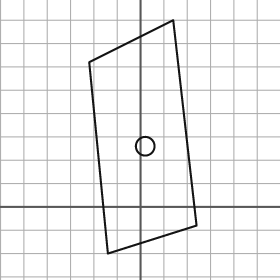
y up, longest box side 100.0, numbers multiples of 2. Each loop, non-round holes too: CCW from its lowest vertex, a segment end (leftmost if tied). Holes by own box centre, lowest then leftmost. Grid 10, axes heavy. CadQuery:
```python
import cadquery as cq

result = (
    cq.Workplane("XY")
    .moveTo(-14.0, -20.0)
    .lineTo(24.0, -8.0)
    .lineTo(14.0, 80.0)
    .lineTo(-22.0, 62.0)
    .close()
    .moveTo(2.0, 26.0)
    .circle(4.0)
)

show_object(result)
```